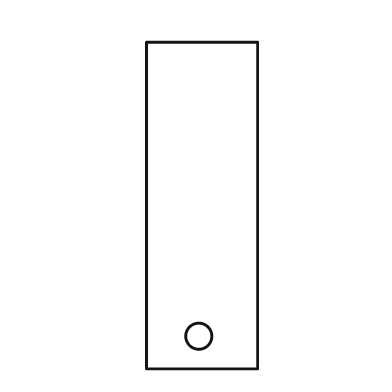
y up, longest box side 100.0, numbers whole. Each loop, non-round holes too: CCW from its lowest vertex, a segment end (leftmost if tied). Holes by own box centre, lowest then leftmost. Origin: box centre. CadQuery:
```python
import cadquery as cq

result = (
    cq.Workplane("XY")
    .moveTo(-17.0, -50.0)
    .lineTo(17.0, -50.0)
    .lineTo(17.0, 50.0)
    .lineTo(-17.0, 50.0)
    .close()
    .moveTo(-1.0, -40.0)
    .circle(4.0)
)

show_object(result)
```